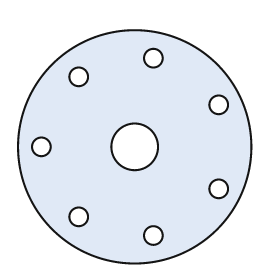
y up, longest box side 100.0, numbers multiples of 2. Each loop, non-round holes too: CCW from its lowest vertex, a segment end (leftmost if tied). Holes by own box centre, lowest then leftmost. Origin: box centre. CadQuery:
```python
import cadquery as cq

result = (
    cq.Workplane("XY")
    .moveTo(0.0, 0.0)
    .circle(50.0)
    .moveTo(8.0, -38.0)
    .circle(4.0)
    .moveTo(-24.0, -30.0)
    .circle(4.0)
    .moveTo(36.0, -18.0)
    .circle(4.0)
    .moveTo(-40.0, 0.0)
    .circle(4.0)
    .moveTo(0.0, 0.0)
    .circle(10.0)
    .moveTo(36.0, 18.0)
    .circle(4.0)
    .moveTo(-24.0, 30.0)
    .circle(4.0)
    .moveTo(8.0, 38.0)
    .circle(4.0)
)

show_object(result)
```